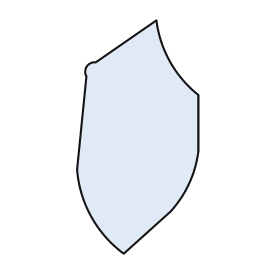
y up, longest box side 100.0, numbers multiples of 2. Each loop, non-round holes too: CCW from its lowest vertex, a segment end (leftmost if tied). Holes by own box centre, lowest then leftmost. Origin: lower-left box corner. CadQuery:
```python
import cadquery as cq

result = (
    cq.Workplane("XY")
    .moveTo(20.0, 0.0)
    .lineTo(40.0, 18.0)
    .threePointArc((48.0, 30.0), (52.0, 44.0))
    .lineTo(52.0, 68.0)
    .threePointArc((40.0, 82.0), (34.0, 100.0))
    .lineTo(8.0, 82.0)
    .threePointArc((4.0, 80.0), (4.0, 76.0))
    .lineTo(0.0, 36.0)
    .threePointArc((6.0, 16.0), (20.0, 0.0))
    .close()
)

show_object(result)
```